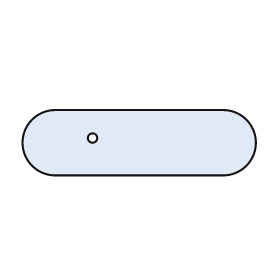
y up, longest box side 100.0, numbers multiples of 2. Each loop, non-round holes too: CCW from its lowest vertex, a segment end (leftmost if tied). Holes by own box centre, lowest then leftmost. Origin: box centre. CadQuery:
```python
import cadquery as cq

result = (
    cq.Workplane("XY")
    .moveTo(-36.0, -14.0)
    .lineTo(36.0, -14.0)
    .threePointArc((50.0, 0.0), (36.0, 14.0))
    .lineTo(-36.0, 14.0)
    .threePointArc((-50.0, 0.0), (-36.0, -14.0))
    .close()
    .moveTo(-20.0, 2.0)
    .circle(2.0)
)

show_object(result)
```